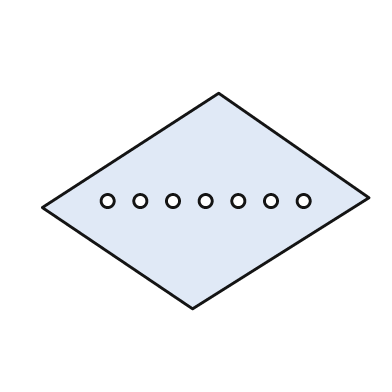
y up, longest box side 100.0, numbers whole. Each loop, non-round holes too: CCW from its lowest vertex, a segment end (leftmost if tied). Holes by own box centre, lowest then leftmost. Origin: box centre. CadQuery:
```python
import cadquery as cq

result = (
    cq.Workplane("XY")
    .moveTo(-4.0, -33.0)
    .lineTo(50.0, 1.0)
    .lineTo(4.0, 33.0)
    .lineTo(-50.0, -2.0)
    .close()
    .moveTo(-30.0, 0.0)
    .circle(2.0)
    .moveTo(-20.0, 0.0)
    .circle(2.0)
    .moveTo(-10.0, 0.0)
    .circle(2.0)
    .moveTo(0.0, 0.0)
    .circle(2.0)
    .moveTo(10.0, 0.0)
    .circle(2.0)
    .moveTo(20.0, 0.0)
    .circle(2.0)
    .moveTo(30.0, 0.0)
    .circle(2.0)
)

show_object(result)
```